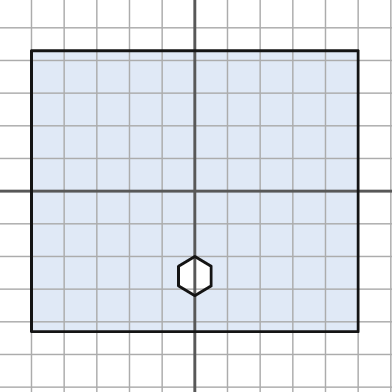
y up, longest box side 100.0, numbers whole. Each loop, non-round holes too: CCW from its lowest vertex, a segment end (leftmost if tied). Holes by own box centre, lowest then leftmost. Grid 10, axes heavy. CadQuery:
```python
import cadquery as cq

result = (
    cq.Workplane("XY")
    .moveTo(-50.0, -43.0)
    .lineTo(50.0, -43.0)
    .lineTo(50.0, 43.0)
    .lineTo(-50.0, 43.0)
    .close()
    .moveTo(0.0, -32.0)
    .lineTo(5.0, -29.0)
    .lineTo(5.0, -23.0)
    .lineTo(0.0, -20.0)
    .lineTo(-5.0, -23.0)
    .lineTo(-5.0, -29.0)
    .close()
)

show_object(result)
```